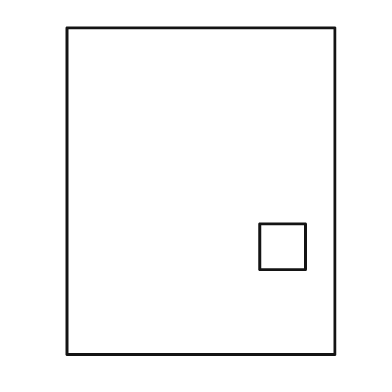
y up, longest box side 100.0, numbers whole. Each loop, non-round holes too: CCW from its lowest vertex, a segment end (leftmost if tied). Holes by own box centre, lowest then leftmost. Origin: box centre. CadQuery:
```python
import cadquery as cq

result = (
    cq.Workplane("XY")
    .moveTo(-41.0, -50.0)
    .lineTo(41.0, -50.0)
    .lineTo(41.0, 50.0)
    .lineTo(-41.0, 50.0)
    .close()
    .moveTo(18.0, -24.0)
    .lineTo(32.0, -24.0)
    .lineTo(32.0, -10.0)
    .lineTo(18.0, -10.0)
    .close()
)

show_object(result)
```